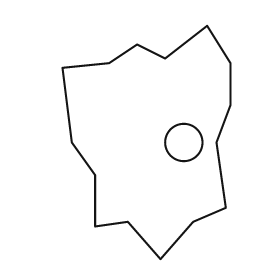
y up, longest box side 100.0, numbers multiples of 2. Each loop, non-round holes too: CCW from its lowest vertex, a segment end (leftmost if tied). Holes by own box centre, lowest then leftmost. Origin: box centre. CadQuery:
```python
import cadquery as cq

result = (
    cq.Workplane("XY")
    .moveTo(6.0, -50.0)
    .lineTo(20.0, -34.0)
    .lineTo(34.0, -28.0)
    .lineTo(30.0, 0.0)
    .lineTo(36.0, 16.0)
    .lineTo(36.0, 34.0)
    .lineTo(26.0, 50.0)
    .lineTo(8.0, 36.0)
    .lineTo(-4.0, 42.0)
    .lineTo(-16.0, 34.0)
    .lineTo(-36.0, 32.0)
    .lineTo(-32.0, 0.0)
    .lineTo(-22.0, -14.0)
    .lineTo(-22.0, -36.0)
    .lineTo(-8.0, -34.0)
    .close()
    .moveTo(16.0, 0.0)
    .circle(8.0)
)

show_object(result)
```